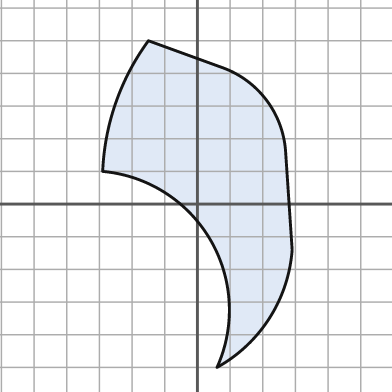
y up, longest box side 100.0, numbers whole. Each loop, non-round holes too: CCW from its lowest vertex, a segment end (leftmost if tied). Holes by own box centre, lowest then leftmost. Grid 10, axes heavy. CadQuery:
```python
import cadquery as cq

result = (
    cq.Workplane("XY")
    .moveTo(6.0, -50.0)
    .threePointArc((22.0, -35.0), (29.0, -14.0))
    .lineTo(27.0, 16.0)
    .threePointArc((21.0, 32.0), (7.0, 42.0))
    .lineTo(-15.0, 50.0)
    .threePointArc((-25.0, 31.0), (-29.0, 10.0))
    .threePointArc((4.0, -11.0), (6.0, -50.0))
    .close()
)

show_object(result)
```